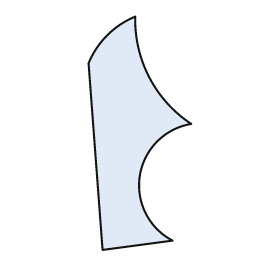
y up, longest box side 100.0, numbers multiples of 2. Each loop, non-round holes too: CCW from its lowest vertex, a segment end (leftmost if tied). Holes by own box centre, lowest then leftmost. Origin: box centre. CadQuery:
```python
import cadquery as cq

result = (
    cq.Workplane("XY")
    .moveTo(-16.0, -50.0)
    .lineTo(14.0, -46.0)
    .threePointArc((0.0, -18.0), (22.0, 4.0))
    .threePointArc((4.0, 24.0), (-2.0, 50.0))
    .threePointArc((-14.0, 42.0), (-22.0, 30.0))
    .close()
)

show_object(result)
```